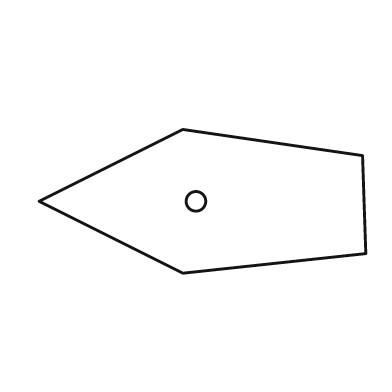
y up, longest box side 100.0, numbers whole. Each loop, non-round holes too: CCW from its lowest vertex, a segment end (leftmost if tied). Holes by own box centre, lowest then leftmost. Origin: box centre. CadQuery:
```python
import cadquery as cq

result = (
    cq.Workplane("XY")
    .moveTo(-6.0, -22.0)
    .lineTo(50.0, -16.0)
    .lineTo(49.0, 14.0)
    .lineTo(-6.0, 22.0)
    .lineTo(-50.0, 0.0)
    .close()
    .moveTo(-2.0, 0.0)
    .circle(3.0)
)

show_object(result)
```